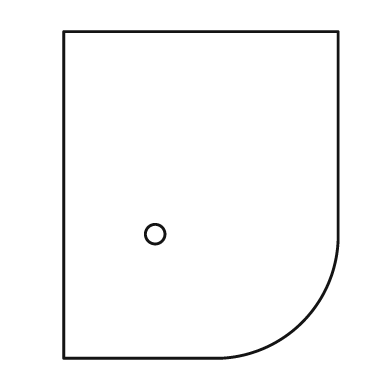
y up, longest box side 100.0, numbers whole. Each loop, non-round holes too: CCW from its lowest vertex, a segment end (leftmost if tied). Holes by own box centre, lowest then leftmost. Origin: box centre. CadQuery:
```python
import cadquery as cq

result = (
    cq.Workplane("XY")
    .moveTo(-42.0, -50.0)
    .lineTo(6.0, -50.0)
    .threePointArc((31.0, -39.0), (42.0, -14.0))
    .lineTo(42.0, 50.0)
    .lineTo(-42.0, 50.0)
    .close()
    .moveTo(-14.0, -12.0)
    .circle(3.0)
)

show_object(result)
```